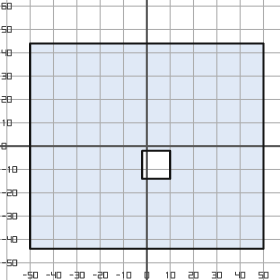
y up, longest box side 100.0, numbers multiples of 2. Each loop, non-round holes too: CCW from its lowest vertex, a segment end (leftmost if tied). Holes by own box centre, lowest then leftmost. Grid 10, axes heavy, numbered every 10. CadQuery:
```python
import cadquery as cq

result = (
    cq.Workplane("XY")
    .moveTo(-50.0, -44.0)
    .lineTo(50.0, -44.0)
    .lineTo(50.0, 44.0)
    .lineTo(-50.0, 44.0)
    .close()
    .moveTo(-2.0, -14.0)
    .lineTo(10.0, -14.0)
    .lineTo(10.0, -2.0)
    .lineTo(-2.0, -2.0)
    .close()
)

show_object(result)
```